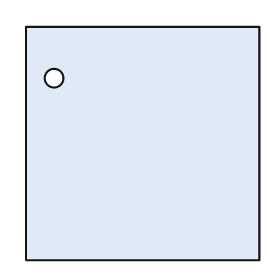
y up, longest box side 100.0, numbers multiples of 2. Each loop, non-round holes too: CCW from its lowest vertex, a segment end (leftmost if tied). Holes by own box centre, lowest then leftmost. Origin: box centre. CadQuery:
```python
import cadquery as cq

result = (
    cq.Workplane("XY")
    .moveTo(-50.0, -50.0)
    .lineTo(50.0, -50.0)
    .lineTo(50.0, 50.0)
    .lineTo(-50.0, 50.0)
    .close()
    .moveTo(-38.0, 28.0)
    .circle(4.0)
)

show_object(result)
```